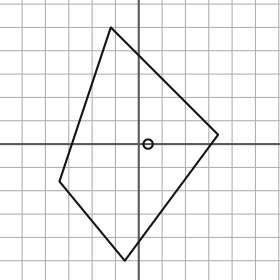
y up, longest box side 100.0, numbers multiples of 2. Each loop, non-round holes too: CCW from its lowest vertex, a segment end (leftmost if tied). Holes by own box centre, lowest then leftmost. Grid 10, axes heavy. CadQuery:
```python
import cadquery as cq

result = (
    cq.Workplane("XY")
    .moveTo(-6.0, -50.0)
    .lineTo(34.0, 4.0)
    .lineTo(-12.0, 50.0)
    .lineTo(-34.0, -16.0)
    .close()
    .moveTo(4.0, 0.0)
    .circle(2.0)
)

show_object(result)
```